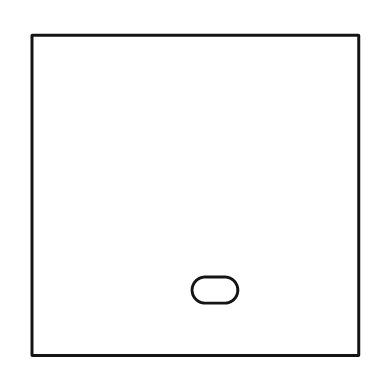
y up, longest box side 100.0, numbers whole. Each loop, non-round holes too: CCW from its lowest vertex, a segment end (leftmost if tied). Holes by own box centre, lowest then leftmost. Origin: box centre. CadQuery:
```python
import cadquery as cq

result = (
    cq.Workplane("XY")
    .moveTo(-50.0, -49.0)
    .lineTo(50.0, -49.0)
    .lineTo(50.0, 49.0)
    .lineTo(-50.0, 49.0)
    .close()
    .moveTo(3.0, -33.0)
    .lineTo(9.0, -33.0)
    .threePointArc((13.0, -29.0), (9.0, -25.0))
    .lineTo(3.0, -25.0)
    .threePointArc((-1.0, -29.0), (3.0, -33.0))
    .close()
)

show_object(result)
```